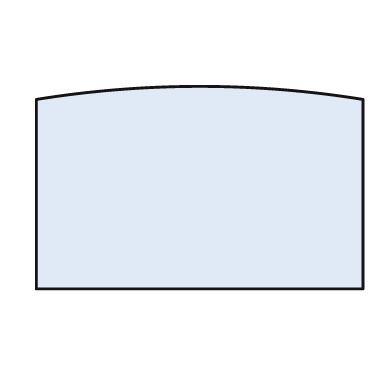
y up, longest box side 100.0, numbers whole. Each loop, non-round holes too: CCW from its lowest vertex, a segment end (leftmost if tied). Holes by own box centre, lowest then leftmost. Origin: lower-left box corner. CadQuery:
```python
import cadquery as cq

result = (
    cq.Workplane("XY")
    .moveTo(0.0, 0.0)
    .lineTo(100.0, 0.0)
    .lineTo(100.0, 58.0)
    .threePointArc((50.0, 62.0), (0.0, 58.0))
    .close()
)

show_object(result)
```